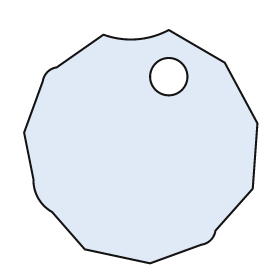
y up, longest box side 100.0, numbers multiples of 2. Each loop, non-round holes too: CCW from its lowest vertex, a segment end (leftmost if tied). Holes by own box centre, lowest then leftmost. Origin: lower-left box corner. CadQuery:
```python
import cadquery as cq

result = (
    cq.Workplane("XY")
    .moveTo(54.0, 0.0)
    .lineTo(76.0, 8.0)
    .threePointArc((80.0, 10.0), (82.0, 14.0))
    .lineTo(98.0, 32.0)
    .lineTo(100.0, 60.0)
    .lineTo(86.0, 86.0)
    .lineTo(62.0, 100.0)
    .threePointArc((48.0, 96.0), (34.0, 98.0))
    .lineTo(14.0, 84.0)
    .threePointArc((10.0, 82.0), (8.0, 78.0))
    .lineTo(0.0, 56.0)
    .lineTo(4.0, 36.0)
    .threePointArc((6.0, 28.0), (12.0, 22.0))
    .lineTo(26.0, 6.0)
    .close()
    .moveTo(62.0, 80.0)
    .circle(8.0)
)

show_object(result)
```